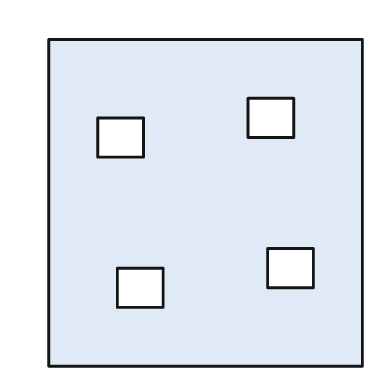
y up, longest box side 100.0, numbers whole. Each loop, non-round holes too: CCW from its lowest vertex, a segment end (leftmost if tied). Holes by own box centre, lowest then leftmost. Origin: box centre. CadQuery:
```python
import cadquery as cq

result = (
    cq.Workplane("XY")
    .moveTo(-48.0, -50.0)
    .lineTo(48.0, -50.0)
    .lineTo(48.0, 50.0)
    .lineTo(-48.0, 50.0)
    .close()
    .moveTo(-27.0, -32.0)
    .lineTo(-13.0, -32.0)
    .lineTo(-13.0, -20.0)
    .lineTo(-27.0, -20.0)
    .close()
    .moveTo(19.0, -26.0)
    .lineTo(33.0, -26.0)
    .lineTo(33.0, -14.0)
    .lineTo(19.0, -14.0)
    .close()
    .moveTo(-33.0, 14.0)
    .lineTo(-19.0, 14.0)
    .lineTo(-19.0, 26.0)
    .lineTo(-33.0, 26.0)
    .close()
    .moveTo(13.0, 20.0)
    .lineTo(27.0, 20.0)
    .lineTo(27.0, 32.0)
    .lineTo(13.0, 32.0)
    .close()
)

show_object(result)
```